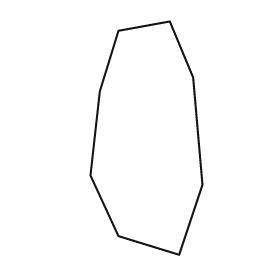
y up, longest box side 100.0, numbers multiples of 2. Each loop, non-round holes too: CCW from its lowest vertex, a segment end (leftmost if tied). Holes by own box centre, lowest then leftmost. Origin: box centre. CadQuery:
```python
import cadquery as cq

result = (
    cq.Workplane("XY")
    .moveTo(14.0, -50.0)
    .lineTo(24.0, -20.0)
    .lineTo(20.0, 26.0)
    .lineTo(10.0, 50.0)
    .lineTo(-12.0, 46.0)
    .lineTo(-20.0, 20.0)
    .lineTo(-24.0, -16.0)
    .lineTo(-12.0, -42.0)
    .close()
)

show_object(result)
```